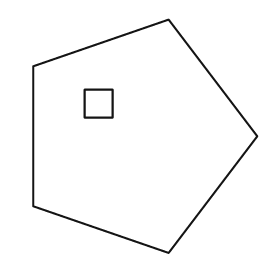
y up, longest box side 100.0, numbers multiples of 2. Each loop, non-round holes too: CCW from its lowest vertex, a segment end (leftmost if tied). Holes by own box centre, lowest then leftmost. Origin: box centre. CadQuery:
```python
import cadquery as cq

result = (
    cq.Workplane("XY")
    .moveTo(10.0, -50.0)
    .lineTo(48.0, 0.0)
    .lineTo(10.0, 50.0)
    .lineTo(-48.0, 30.0)
    .lineTo(-48.0, -30.0)
    .close()
    .moveTo(-26.0, 8.0)
    .lineTo(-14.0, 8.0)
    .lineTo(-14.0, 20.0)
    .lineTo(-26.0, 20.0)
    .close()
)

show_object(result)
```